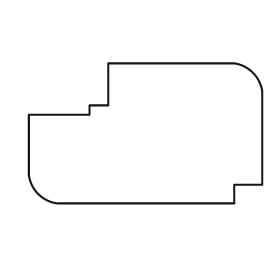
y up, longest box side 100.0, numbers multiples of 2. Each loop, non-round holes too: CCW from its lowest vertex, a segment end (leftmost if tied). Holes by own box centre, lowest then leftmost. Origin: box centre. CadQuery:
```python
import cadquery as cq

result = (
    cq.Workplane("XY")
    .moveTo(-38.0, -30.0)
    .lineTo(38.0, -30.0)
    .lineTo(38.0, -22.0)
    .lineTo(50.0, -22.0)
    .lineTo(50.0, 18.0)
    .threePointArc((46.0, 26.0), (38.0, 30.0))
    .lineTo(-16.0, 30.0)
    .lineTo(-16.0, 12.0)
    .lineTo(-24.0, 12.0)
    .lineTo(-24.0, 8.0)
    .lineTo(-50.0, 8.0)
    .lineTo(-50.0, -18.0)
    .threePointArc((-46.0, -26.0), (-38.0, -30.0))
    .close()
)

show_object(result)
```